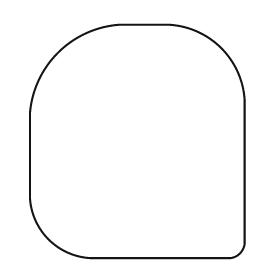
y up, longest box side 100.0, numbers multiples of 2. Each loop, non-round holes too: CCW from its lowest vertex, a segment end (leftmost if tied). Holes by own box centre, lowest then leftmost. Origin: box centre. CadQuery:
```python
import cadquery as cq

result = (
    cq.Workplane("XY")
    .moveTo(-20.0, -50.0)
    .lineTo(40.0, -50.0)
    .threePointArc((44.0, -48.0), (46.0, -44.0))
    .lineTo(46.0, 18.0)
    .threePointArc((36.0, 40.0), (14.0, 50.0))
    .lineTo(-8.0, 50.0)
    .threePointArc((-34.0, 38.0), (-46.0, 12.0))
    .lineTo(-46.0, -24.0)
    .threePointArc((-38.0, -42.0), (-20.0, -50.0))
    .close()
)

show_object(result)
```